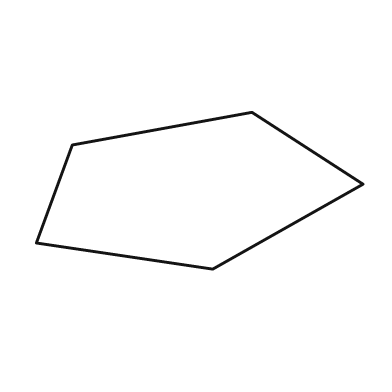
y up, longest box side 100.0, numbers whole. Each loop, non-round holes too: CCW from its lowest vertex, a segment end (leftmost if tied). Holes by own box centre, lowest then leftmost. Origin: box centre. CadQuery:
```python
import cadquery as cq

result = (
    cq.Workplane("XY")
    .moveTo(4.0, -24.0)
    .lineTo(50.0, 2.0)
    .lineTo(16.0, 24.0)
    .lineTo(-39.0, 14.0)
    .lineTo(-50.0, -16.0)
    .close()
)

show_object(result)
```